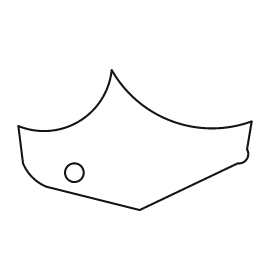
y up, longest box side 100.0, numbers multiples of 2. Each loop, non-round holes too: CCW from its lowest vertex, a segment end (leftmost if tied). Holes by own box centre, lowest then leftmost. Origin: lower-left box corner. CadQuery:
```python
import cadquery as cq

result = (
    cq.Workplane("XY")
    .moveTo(52.0, 0.0)
    .lineTo(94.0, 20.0)
    .threePointArc((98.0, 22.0), (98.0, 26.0))
    .lineTo(100.0, 38.0)
    .threePointArc((66.0, 38.0), (40.0, 60.0))
    .threePointArc((26.0, 38.0), (0.0, 36.0))
    .lineTo(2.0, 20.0)
    .threePointArc((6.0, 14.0), (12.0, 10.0))
    .close()
    .moveTo(24.0, 16.0)
    .circle(4.0)
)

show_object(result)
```